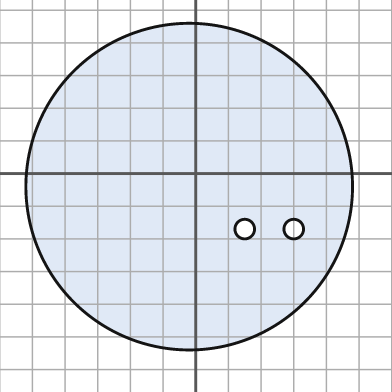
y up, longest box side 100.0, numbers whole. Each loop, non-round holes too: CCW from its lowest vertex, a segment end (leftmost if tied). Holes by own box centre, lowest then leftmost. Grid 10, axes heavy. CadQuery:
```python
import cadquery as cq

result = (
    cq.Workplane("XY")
    .moveTo(-2.0, -4.0)
    .circle(50.0)
    .moveTo(15.0, -17.0)
    .circle(3.0)
    .moveTo(30.0, -17.0)
    .circle(3.0)
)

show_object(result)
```